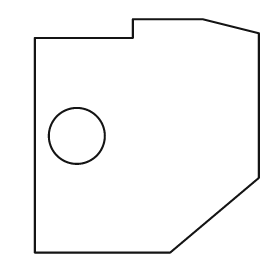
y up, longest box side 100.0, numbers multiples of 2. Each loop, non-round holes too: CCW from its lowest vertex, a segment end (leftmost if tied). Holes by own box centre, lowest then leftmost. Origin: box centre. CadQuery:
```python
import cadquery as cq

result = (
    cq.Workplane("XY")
    .moveTo(-48.0, -50.0)
    .lineTo(10.0, -50.0)
    .lineTo(48.0, -18.0)
    .lineTo(48.0, 44.0)
    .lineTo(24.0, 50.0)
    .lineTo(-6.0, 50.0)
    .lineTo(-6.0, 42.0)
    .lineTo(-48.0, 42.0)
    .close()
    .moveTo(-30.0, 0.0)
    .circle(12.0)
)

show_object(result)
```